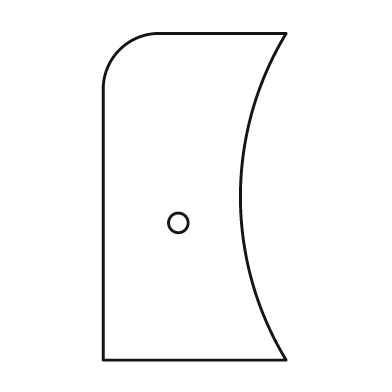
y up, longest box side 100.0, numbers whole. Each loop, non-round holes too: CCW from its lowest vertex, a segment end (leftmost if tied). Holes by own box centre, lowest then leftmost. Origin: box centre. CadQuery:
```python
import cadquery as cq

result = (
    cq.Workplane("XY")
    .moveTo(-28.0, -50.0)
    .lineTo(28.0, -50.0)
    .threePointArc((14.0, 0.0), (28.0, 50.0))
    .lineTo(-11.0, 50.0)
    .threePointArc((-23.0, 45.0), (-28.0, 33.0))
    .close()
    .moveTo(-5.0, -8.0)
    .circle(3.0)
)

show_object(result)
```